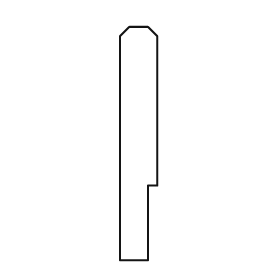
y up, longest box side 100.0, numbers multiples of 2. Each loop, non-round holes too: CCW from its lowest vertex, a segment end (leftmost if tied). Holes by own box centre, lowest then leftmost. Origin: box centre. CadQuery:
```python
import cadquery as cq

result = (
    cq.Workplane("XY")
    .moveTo(-8.0, -50.0)
    .lineTo(4.0, -50.0)
    .lineTo(4.0, -18.0)
    .lineTo(8.0, -18.0)
    .lineTo(8.0, 46.0)
    .lineTo(4.0, 50.0)
    .lineTo(-4.0, 50.0)
    .lineTo(-8.0, 46.0)
    .close()
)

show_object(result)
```